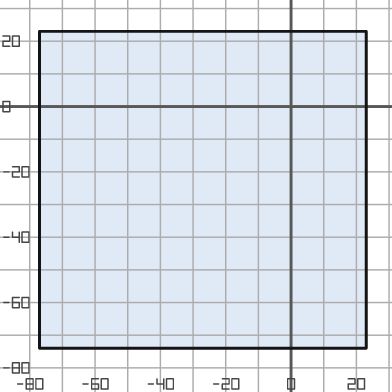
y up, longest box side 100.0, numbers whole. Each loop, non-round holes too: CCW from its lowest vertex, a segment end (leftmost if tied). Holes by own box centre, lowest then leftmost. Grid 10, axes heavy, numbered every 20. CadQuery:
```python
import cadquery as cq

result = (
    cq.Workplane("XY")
    .moveTo(-77.0, -74.0)
    .lineTo(23.0, -74.0)
    .lineTo(23.0, 23.0)
    .lineTo(-77.0, 23.0)
    .close()
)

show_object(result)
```